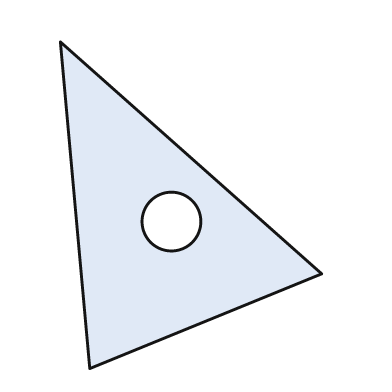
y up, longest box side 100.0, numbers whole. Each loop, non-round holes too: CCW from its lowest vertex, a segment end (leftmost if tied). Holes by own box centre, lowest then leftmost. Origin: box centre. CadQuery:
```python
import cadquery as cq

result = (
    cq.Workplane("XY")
    .moveTo(-31.0, -50.0)
    .lineTo(40.0, -21.0)
    .lineTo(-40.0, 50.0)
    .close()
    .moveTo(-6.0, -5.0)
    .circle(9.0)
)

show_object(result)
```